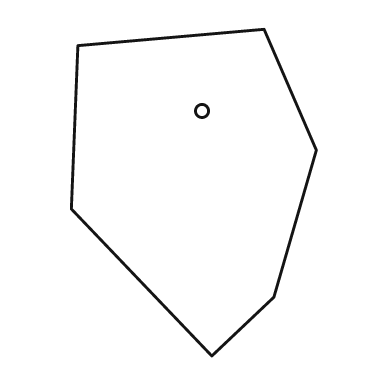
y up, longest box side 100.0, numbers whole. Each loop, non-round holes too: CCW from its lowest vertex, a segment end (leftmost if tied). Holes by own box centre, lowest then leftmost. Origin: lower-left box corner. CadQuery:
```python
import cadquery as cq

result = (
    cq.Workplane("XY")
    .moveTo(43.0, 0.0)
    .lineTo(62.0, 18.0)
    .lineTo(75.0, 63.0)
    .lineTo(59.0, 100.0)
    .lineTo(2.0, 95.0)
    .lineTo(0.0, 45.0)
    .close()
    .moveTo(40.0, 75.0)
    .circle(2.0)
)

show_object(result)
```